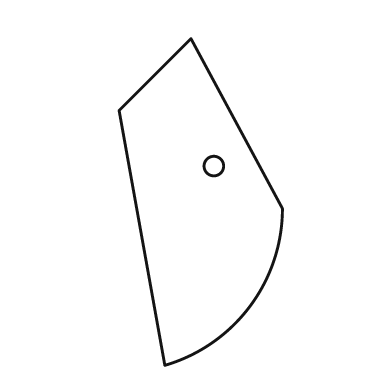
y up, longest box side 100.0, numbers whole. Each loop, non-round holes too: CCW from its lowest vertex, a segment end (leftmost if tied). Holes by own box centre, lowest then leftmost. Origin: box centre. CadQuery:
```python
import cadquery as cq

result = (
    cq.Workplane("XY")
    .moveTo(-11.0, -50.0)
    .threePointArc((15.0, -32.0), (25.0, -2.0))
    .lineTo(-3.0, 50.0)
    .lineTo(-25.0, 28.0)
    .close()
    .moveTo(4.0, 11.0)
    .circle(3.0)
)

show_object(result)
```